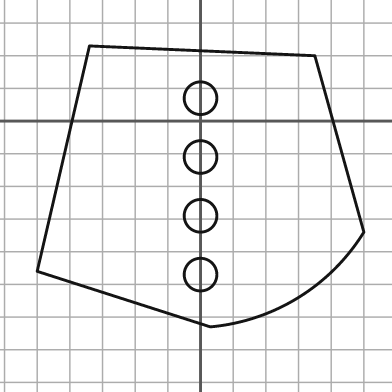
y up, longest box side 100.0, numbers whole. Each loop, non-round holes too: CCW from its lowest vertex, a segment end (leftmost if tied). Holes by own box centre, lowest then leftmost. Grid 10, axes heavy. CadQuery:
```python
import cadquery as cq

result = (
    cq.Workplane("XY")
    .moveTo(3.0, -63.0)
    .threePointArc((30.0, -54.0), (50.0, -34.0))
    .lineTo(35.0, 20.0)
    .lineTo(-34.0, 23.0)
    .lineTo(-50.0, -46.0)
    .close()
    .moveTo(0.0, -47.0)
    .circle(5.0)
    .moveTo(0.0, -29.0)
    .circle(5.0)
    .moveTo(0.0, -11.0)
    .circle(5.0)
    .moveTo(0.0, 7.0)
    .circle(5.0)
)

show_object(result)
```